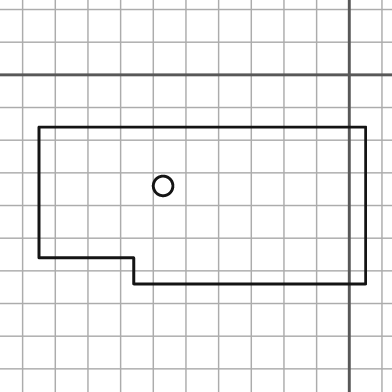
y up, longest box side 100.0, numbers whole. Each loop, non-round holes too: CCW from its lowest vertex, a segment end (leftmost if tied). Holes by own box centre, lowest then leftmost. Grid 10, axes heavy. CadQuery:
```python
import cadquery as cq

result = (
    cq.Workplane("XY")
    .moveTo(-66.0, -64.0)
    .lineTo(5.0, -64.0)
    .lineTo(5.0, -16.0)
    .lineTo(-95.0, -16.0)
    .lineTo(-95.0, -56.0)
    .lineTo(-66.0, -56.0)
    .close()
    .moveTo(-57.0, -34.0)
    .circle(3.0)
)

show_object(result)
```